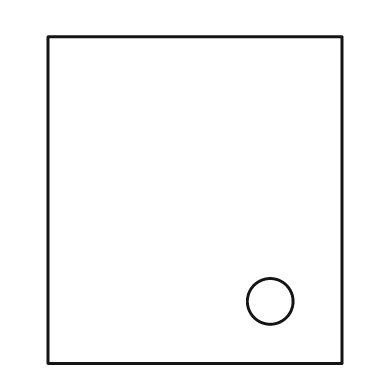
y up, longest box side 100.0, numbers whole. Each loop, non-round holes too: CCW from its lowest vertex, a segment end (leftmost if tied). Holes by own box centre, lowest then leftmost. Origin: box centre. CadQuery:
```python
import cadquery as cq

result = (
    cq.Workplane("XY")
    .moveTo(-45.0, -50.0)
    .lineTo(45.0, -50.0)
    .lineTo(45.0, 50.0)
    .lineTo(-45.0, 50.0)
    .close()
    .moveTo(23.0, -31.0)
    .circle(7.0)
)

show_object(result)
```